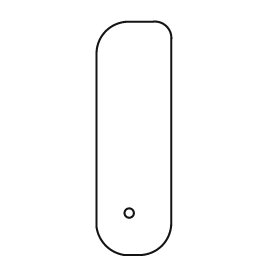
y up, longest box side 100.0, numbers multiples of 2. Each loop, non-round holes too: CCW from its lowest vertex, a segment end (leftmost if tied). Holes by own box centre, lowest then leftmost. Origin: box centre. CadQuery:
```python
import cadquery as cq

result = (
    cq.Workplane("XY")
    .moveTo(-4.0, -50.0)
    .lineTo(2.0, -50.0)
    .threePointArc((12.0, -46.0), (16.0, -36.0))
    .lineTo(16.0, 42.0)
    .threePointArc((14.0, 48.0), (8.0, 50.0))
    .lineTo(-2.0, 50.0)
    .threePointArc((-12.0, 46.0), (-16.0, 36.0))
    .lineTo(-16.0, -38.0)
    .threePointArc((-12.0, -46.0), (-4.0, -50.0))
    .close()
    .moveTo(-2.0, -32.0)
    .circle(2.0)
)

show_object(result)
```